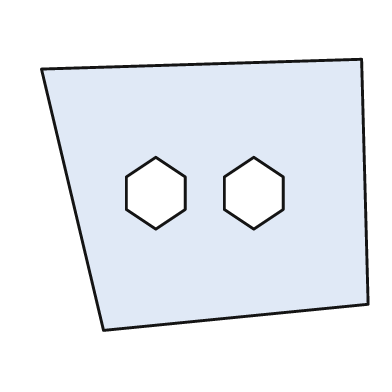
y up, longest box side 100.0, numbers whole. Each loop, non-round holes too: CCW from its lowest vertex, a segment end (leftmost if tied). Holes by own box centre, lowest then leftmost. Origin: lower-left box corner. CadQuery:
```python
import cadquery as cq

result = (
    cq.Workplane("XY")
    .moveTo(19.0, 0.0)
    .lineTo(100.0, 8.0)
    .lineTo(98.0, 83.0)
    .lineTo(0.0, 80.0)
    .close()
    .moveTo(35.0, 31.0)
    .lineTo(44.0, 37.0)
    .lineTo(44.0, 47.0)
    .lineTo(35.0, 53.0)
    .lineTo(26.0, 47.0)
    .lineTo(26.0, 37.0)
    .close()
    .moveTo(65.0, 31.0)
    .lineTo(74.0, 37.0)
    .lineTo(74.0, 47.0)
    .lineTo(65.0, 53.0)
    .lineTo(56.0, 47.0)
    .lineTo(56.0, 37.0)
    .close()
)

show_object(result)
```